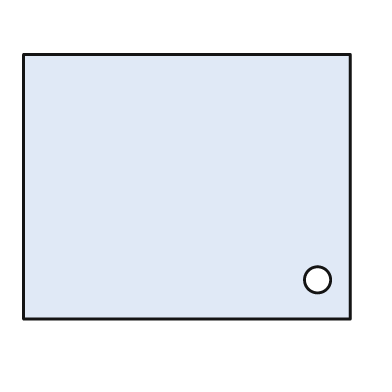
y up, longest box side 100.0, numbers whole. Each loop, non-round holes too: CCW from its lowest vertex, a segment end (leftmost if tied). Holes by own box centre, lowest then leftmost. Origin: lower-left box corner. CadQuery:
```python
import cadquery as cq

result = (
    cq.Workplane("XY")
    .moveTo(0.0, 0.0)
    .lineTo(100.0, 0.0)
    .lineTo(100.0, 81.0)
    .lineTo(0.0, 81.0)
    .close()
    .moveTo(90.0, 12.0)
    .circle(4.0)
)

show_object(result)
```